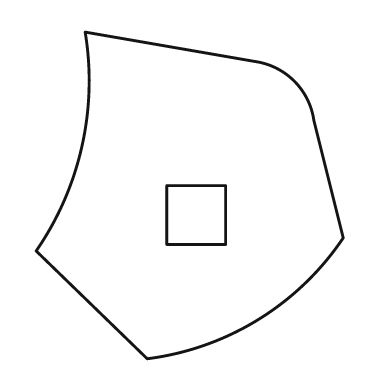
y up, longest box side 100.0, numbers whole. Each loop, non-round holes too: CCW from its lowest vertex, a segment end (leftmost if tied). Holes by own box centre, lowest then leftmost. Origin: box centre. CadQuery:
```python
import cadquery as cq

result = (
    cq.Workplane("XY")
    .moveTo(-13.0, -50.0)
    .threePointArc((21.0, -38.0), (47.0, -13.0))
    .lineTo(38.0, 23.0)
    .threePointArc((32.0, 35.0), (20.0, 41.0))
    .lineTo(-32.0, 50.0)
    .threePointArc((-33.0, 15.0), (-47.0, -17.0))
    .close()
    .moveTo(-7.0, -15.0)
    .lineTo(11.0, -15.0)
    .lineTo(11.0, 3.0)
    .lineTo(-7.0, 3.0)
    .close()
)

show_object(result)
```